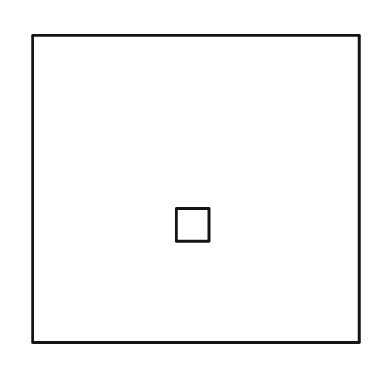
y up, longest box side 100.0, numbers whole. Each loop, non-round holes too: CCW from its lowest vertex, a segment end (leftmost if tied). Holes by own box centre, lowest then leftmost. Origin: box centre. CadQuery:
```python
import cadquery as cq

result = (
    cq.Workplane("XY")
    .moveTo(-50.0, -47.0)
    .lineTo(50.0, -47.0)
    .lineTo(50.0, 47.0)
    .lineTo(-50.0, 47.0)
    .close()
    .moveTo(-6.0, -16.0)
    .lineTo(4.0, -16.0)
    .lineTo(4.0, -6.0)
    .lineTo(-6.0, -6.0)
    .close()
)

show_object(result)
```